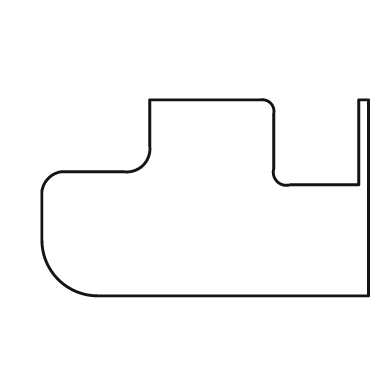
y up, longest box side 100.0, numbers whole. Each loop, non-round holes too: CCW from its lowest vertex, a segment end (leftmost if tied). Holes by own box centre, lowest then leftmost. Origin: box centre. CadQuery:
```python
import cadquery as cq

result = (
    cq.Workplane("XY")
    .moveTo(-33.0, -30.0)
    .lineTo(50.0, -30.0)
    .lineTo(50.0, 30.0)
    .lineTo(47.0, 30.0)
    .lineTo(47.0, 4.0)
    .lineTo(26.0, 4.0)
    .threePointArc((22.0, 5.0), (21.0, 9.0))
    .lineTo(21.0, 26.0)
    .threePointArc((20.0, 29.0), (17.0, 30.0))
    .lineTo(-17.0, 30.0)
    .lineTo(-17.0, 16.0)
    .threePointArc((-19.0, 10.0), (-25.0, 8.0))
    .lineTo(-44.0, 8.0)
    .threePointArc((-48.0, 6.0), (-50.0, 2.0))
    .lineTo(-50.0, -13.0)
    .threePointArc((-45.0, -25.0), (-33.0, -30.0))
    .close()
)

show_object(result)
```